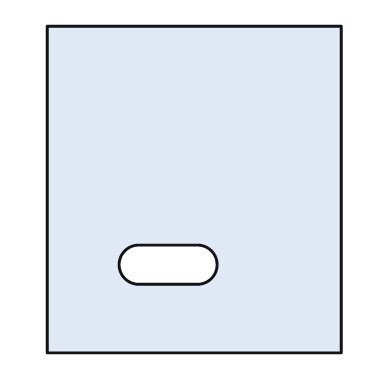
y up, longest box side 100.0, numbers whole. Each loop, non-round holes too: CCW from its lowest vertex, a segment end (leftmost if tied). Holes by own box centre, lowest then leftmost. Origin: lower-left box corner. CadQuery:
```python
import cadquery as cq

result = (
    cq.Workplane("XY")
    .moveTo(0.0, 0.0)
    .lineTo(90.0, 0.0)
    .lineTo(90.0, 100.0)
    .lineTo(0.0, 100.0)
    .close()
    .moveTo(28.0, 21.0)
    .lineTo(46.0, 21.0)
    .threePointArc((52.0, 27.0), (46.0, 33.0))
    .lineTo(28.0, 33.0)
    .threePointArc((22.0, 27.0), (28.0, 21.0))
    .close()
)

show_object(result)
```